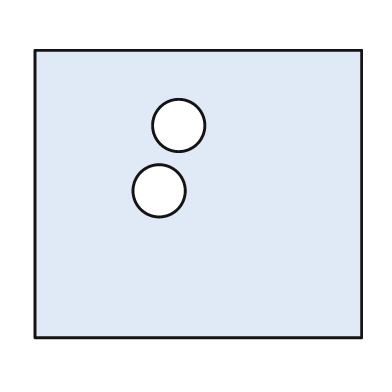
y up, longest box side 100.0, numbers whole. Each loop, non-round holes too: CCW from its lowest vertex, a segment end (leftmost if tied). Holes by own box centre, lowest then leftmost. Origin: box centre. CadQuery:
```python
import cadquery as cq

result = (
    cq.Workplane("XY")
    .moveTo(-50.0, -44.0)
    .lineTo(50.0, -44.0)
    .lineTo(50.0, 44.0)
    .lineTo(-50.0, 44.0)
    .close()
    .moveTo(-12.0, 1.0)
    .circle(8.0)
    .moveTo(-6.0, 21.0)
    .circle(8.0)
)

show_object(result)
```